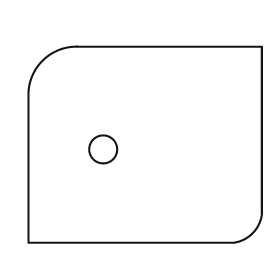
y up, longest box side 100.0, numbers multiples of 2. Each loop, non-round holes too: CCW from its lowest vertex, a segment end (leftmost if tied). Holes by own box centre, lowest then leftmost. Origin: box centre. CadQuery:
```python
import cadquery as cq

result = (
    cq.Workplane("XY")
    .moveTo(-50.0, -42.0)
    .lineTo(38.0, -42.0)
    .threePointArc((46.0, -38.0), (50.0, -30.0))
    .lineTo(50.0, 42.0)
    .lineTo(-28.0, 42.0)
    .threePointArc((-44.0, 36.0), (-50.0, 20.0))
    .close()
    .moveTo(-18.0, -2.0)
    .circle(6.0)
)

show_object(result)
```